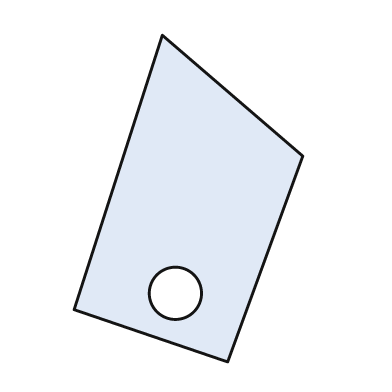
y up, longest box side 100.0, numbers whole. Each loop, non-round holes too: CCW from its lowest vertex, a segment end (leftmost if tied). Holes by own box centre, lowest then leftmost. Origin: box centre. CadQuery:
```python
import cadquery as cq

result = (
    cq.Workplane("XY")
    .moveTo(12.0, -50.0)
    .lineTo(35.0, 13.0)
    .lineTo(-8.0, 50.0)
    .lineTo(-35.0, -34.0)
    .close()
    .moveTo(-4.0, -29.0)
    .circle(8.0)
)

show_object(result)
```